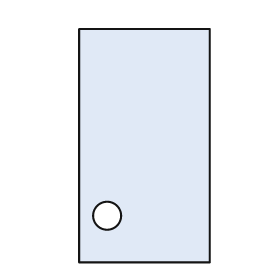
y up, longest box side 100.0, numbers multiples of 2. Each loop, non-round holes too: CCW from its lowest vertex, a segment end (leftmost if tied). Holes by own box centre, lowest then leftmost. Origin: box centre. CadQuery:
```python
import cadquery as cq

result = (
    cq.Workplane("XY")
    .moveTo(-28.0, -50.0)
    .lineTo(28.0, -50.0)
    .lineTo(28.0, 50.0)
    .lineTo(-28.0, 50.0)
    .close()
    .moveTo(-16.0, -30.0)
    .circle(6.0)
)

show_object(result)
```